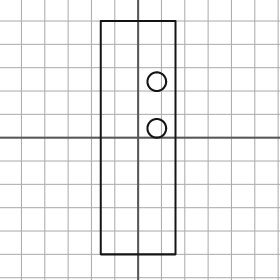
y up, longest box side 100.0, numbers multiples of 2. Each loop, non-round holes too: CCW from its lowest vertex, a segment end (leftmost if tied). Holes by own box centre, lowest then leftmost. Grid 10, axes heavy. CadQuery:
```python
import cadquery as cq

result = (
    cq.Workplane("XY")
    .moveTo(-16.0, -50.0)
    .lineTo(16.0, -50.0)
    .lineTo(16.0, 50.0)
    .lineTo(-16.0, 50.0)
    .close()
    .moveTo(8.0, 4.0)
    .circle(4.0)
    .moveTo(8.0, 24.0)
    .circle(4.0)
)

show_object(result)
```